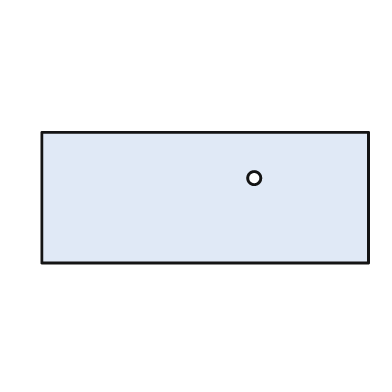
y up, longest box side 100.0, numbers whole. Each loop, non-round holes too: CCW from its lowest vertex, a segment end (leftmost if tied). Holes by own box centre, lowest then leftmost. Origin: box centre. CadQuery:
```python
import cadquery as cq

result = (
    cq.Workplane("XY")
    .moveTo(-50.0, -20.0)
    .lineTo(50.0, -20.0)
    .lineTo(50.0, 20.0)
    .lineTo(-50.0, 20.0)
    .close()
    .moveTo(15.0, 6.0)
    .circle(2.0)
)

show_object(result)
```